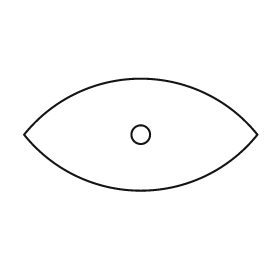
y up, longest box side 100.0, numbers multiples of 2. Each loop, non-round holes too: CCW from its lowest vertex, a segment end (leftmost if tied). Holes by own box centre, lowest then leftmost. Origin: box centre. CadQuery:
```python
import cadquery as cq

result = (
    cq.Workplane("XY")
    .moveTo(-50.0, 0.0)
    .threePointArc((0.0, -24.0), (50.0, 0.0))
    .threePointArc((0.0, 24.0), (-50.0, 0.0))
    .close()
    .moveTo(0.0, 0.0)
    .circle(4.0)
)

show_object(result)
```